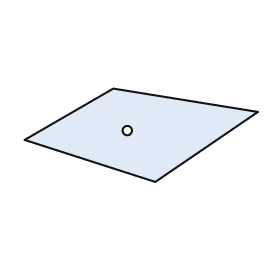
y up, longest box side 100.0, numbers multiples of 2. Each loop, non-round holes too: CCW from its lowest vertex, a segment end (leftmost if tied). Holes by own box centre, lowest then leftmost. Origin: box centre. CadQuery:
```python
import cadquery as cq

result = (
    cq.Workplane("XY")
    .moveTo(6.0, -20.0)
    .lineTo(50.0, 10.0)
    .lineTo(-12.0, 20.0)
    .lineTo(-50.0, -2.0)
    .close()
    .moveTo(-6.0, 2.0)
    .circle(2.0)
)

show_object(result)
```